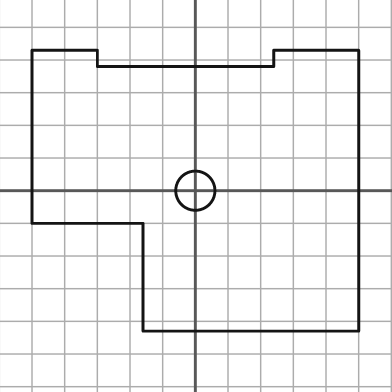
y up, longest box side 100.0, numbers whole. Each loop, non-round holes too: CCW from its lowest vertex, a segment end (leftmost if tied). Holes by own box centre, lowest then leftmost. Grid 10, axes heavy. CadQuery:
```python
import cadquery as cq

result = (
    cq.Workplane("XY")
    .moveTo(-16.0, -43.0)
    .lineTo(50.0, -43.0)
    .lineTo(50.0, 43.0)
    .lineTo(24.0, 43.0)
    .lineTo(24.0, 38.0)
    .lineTo(-30.0, 38.0)
    .lineTo(-30.0, 43.0)
    .lineTo(-50.0, 43.0)
    .lineTo(-50.0, -10.0)
    .lineTo(-16.0, -10.0)
    .close()
    .moveTo(0.0, 0.0)
    .circle(6.0)
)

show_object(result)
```